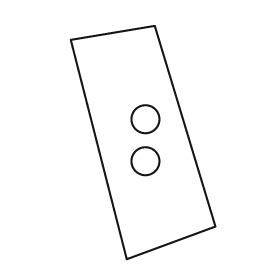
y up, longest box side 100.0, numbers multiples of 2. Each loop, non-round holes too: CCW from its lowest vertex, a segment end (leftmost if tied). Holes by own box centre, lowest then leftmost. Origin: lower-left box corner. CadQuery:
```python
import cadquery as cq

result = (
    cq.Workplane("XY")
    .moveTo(24.0, 0.0)
    .lineTo(62.0, 14.0)
    .lineTo(36.0, 100.0)
    .lineTo(0.0, 94.0)
    .close()
    .moveTo(32.0, 42.0)
    .circle(6.0)
    .moveTo(32.0, 60.0)
    .circle(6.0)
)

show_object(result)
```